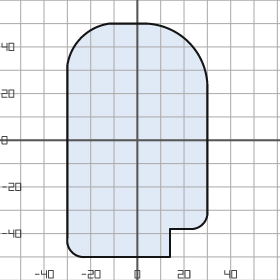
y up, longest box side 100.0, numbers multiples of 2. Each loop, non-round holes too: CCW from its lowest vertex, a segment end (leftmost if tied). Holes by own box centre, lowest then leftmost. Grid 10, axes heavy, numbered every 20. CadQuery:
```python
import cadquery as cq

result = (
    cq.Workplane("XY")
    .moveTo(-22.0, -50.0)
    .lineTo(14.0, -50.0)
    .lineTo(14.0, -38.0)
    .lineTo(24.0, -38.0)
    .threePointArc((28.0, -36.0), (30.0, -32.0))
    .lineTo(30.0, 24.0)
    .threePointArc((22.0, 42.0), (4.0, 50.0))
    .lineTo(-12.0, 50.0)
    .threePointArc((-24.0, 44.0), (-30.0, 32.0))
    .lineTo(-30.0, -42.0)
    .threePointArc((-28.0, -48.0), (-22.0, -50.0))
    .close()
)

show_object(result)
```